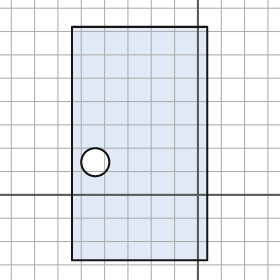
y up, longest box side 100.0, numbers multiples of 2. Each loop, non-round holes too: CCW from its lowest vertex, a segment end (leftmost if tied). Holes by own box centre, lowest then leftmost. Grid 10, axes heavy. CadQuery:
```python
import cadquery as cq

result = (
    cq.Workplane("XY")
    .moveTo(-54.0, -28.0)
    .lineTo(4.0, -28.0)
    .lineTo(4.0, 72.0)
    .lineTo(-54.0, 72.0)
    .close()
    .moveTo(-44.0, 14.0)
    .circle(6.0)
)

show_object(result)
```